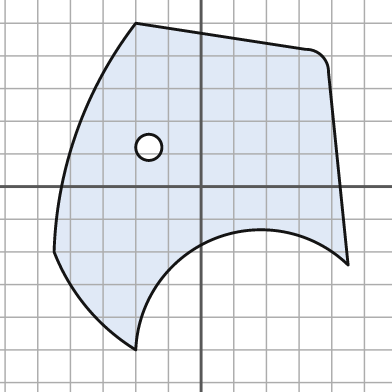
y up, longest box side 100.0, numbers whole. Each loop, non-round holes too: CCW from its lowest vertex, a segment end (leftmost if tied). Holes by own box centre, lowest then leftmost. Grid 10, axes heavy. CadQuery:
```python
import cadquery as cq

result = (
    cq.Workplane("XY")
    .moveTo(-20.0, -50.0)
    .threePointArc((4.0, -16.0), (45.0, -24.0))
    .lineTo(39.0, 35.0)
    .threePointArc((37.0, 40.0), (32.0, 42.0))
    .lineTo(-20.0, 50.0)
    .threePointArc((-38.0, 17.0), (-45.0, -20.0))
    .threePointArc((-35.0, -37.0), (-20.0, -50.0))
    .close()
    .moveTo(-16.0, 12.0)
    .circle(4.0)
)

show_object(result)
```